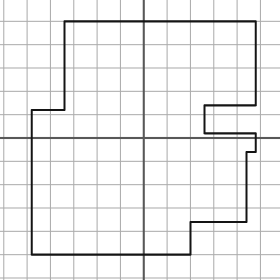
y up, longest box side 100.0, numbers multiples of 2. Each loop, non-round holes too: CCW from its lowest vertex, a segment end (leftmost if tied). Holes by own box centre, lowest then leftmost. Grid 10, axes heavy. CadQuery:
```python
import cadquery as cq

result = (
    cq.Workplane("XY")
    .moveTo(-48.0, -50.0)
    .lineTo(20.0, -50.0)
    .lineTo(20.0, -36.0)
    .lineTo(44.0, -36.0)
    .lineTo(44.0, -6.0)
    .lineTo(48.0, -6.0)
    .lineTo(48.0, 2.0)
    .lineTo(26.0, 2.0)
    .lineTo(26.0, 14.0)
    .lineTo(48.0, 14.0)
    .lineTo(48.0, 50.0)
    .lineTo(-34.0, 50.0)
    .lineTo(-34.0, 12.0)
    .lineTo(-48.0, 12.0)
    .close()
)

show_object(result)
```